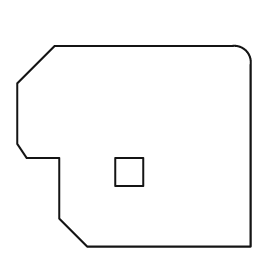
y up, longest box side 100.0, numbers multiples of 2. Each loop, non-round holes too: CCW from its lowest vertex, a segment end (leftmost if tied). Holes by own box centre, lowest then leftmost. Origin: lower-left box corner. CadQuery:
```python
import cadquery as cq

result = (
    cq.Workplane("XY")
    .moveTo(30.0, 0.0)
    .lineTo(100.0, 0.0)
    .lineTo(100.0, 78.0)
    .threePointArc((98.0, 84.0), (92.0, 86.0))
    .lineTo(16.0, 86.0)
    .lineTo(0.0, 70.0)
    .lineTo(0.0, 44.0)
    .lineTo(4.0, 38.0)
    .lineTo(18.0, 38.0)
    .lineTo(18.0, 12.0)
    .close()
    .moveTo(42.0, 26.0)
    .lineTo(54.0, 26.0)
    .lineTo(54.0, 38.0)
    .lineTo(42.0, 38.0)
    .close()
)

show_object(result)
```